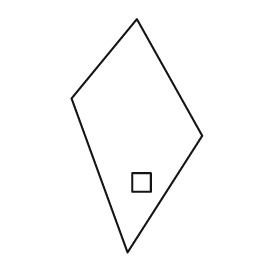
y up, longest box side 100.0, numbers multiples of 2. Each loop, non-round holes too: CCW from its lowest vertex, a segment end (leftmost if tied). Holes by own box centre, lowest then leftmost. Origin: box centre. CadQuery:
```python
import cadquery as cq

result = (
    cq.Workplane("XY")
    .moveTo(-4.0, -50.0)
    .lineTo(28.0, 0.0)
    .lineTo(0.0, 50.0)
    .lineTo(-28.0, 16.0)
    .close()
    .moveTo(-2.0, -24.0)
    .lineTo(6.0, -24.0)
    .lineTo(6.0, -16.0)
    .lineTo(-2.0, -16.0)
    .close()
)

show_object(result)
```